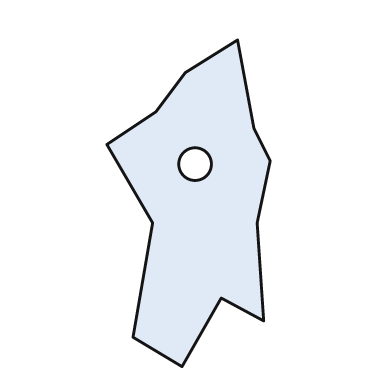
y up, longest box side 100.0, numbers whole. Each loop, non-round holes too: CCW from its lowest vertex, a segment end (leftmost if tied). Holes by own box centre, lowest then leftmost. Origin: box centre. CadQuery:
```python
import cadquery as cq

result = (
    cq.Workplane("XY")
    .moveTo(-2.0, -50.0)
    .lineTo(10.0, -29.0)
    .lineTo(23.0, -36.0)
    .lineTo(21.0, -6.0)
    .lineTo(25.0, 13.0)
    .lineTo(20.0, 23.0)
    .lineTo(15.0, 50.0)
    .lineTo(-1.0, 40.0)
    .lineTo(-10.0, 28.0)
    .lineTo(-25.0, 18.0)
    .lineTo(-11.0, -6.0)
    .lineTo(-17.0, -41.0)
    .close()
    .moveTo(2.0, 12.0)
    .circle(5.0)
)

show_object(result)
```